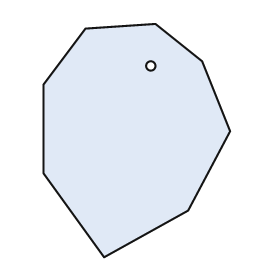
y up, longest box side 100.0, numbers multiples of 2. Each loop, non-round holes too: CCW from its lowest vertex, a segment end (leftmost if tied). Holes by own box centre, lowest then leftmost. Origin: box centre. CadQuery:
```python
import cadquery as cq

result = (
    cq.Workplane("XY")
    .moveTo(-14.0, -50.0)
    .lineTo(22.0, -30.0)
    .lineTo(40.0, 4.0)
    .lineTo(28.0, 34.0)
    .lineTo(8.0, 50.0)
    .lineTo(-22.0, 48.0)
    .lineTo(-40.0, 24.0)
    .lineTo(-40.0, -14.0)
    .close()
    .moveTo(6.0, 32.0)
    .circle(2.0)
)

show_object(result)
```